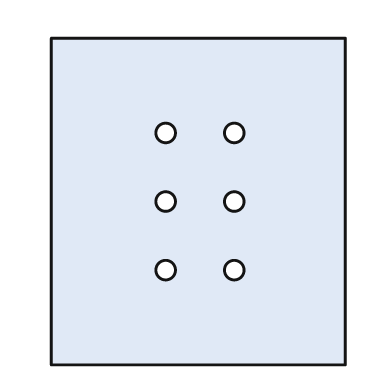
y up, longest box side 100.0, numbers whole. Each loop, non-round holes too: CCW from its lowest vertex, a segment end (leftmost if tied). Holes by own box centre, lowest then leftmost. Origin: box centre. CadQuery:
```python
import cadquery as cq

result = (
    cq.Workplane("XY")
    .moveTo(-45.0, -50.0)
    .lineTo(45.0, -50.0)
    .lineTo(45.0, 50.0)
    .lineTo(-45.0, 50.0)
    .close()
    .moveTo(-10.0, -21.0)
    .circle(3.0)
    .moveTo(11.0, -21.0)
    .circle(3.0)
    .moveTo(-10.0, 0.0)
    .circle(3.0)
    .moveTo(11.0, 0.0)
    .circle(3.0)
    .moveTo(-10.0, 21.0)
    .circle(3.0)
    .moveTo(11.0, 21.0)
    .circle(3.0)
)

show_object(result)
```